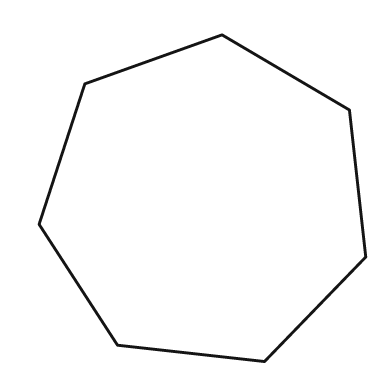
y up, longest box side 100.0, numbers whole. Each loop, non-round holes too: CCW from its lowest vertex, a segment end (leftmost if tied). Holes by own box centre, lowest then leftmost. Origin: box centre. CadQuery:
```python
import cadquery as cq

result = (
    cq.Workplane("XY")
    .moveTo(19.0, -50.0)
    .lineTo(50.0, -18.0)
    .lineTo(45.0, 27.0)
    .lineTo(6.0, 50.0)
    .lineTo(-36.0, 35.0)
    .lineTo(-50.0, -8.0)
    .lineTo(-26.0, -45.0)
    .close()
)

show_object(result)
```